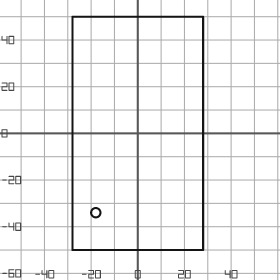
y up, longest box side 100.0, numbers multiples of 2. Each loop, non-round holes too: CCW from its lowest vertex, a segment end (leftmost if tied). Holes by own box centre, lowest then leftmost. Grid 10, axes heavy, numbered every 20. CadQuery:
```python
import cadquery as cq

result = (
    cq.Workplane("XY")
    .moveTo(-28.0, -50.0)
    .lineTo(28.0, -50.0)
    .lineTo(28.0, 50.0)
    .lineTo(-28.0, 50.0)
    .close()
    .moveTo(-18.0, -34.0)
    .circle(2.0)
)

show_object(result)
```